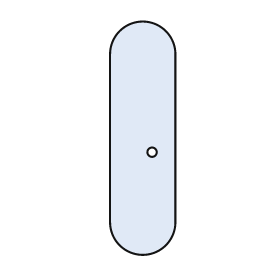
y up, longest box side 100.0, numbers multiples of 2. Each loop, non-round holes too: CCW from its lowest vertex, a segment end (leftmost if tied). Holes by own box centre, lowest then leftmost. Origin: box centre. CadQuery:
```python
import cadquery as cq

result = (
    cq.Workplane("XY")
    .moveTo(-14.0, -36.0)
    .threePointArc((0.0, -50.0), (14.0, -36.0))
    .lineTo(14.0, 36.0)
    .threePointArc((0.0, 50.0), (-14.0, 36.0))
    .close()
    .moveTo(4.0, -6.0)
    .circle(2.0)
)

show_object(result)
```